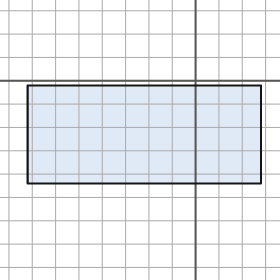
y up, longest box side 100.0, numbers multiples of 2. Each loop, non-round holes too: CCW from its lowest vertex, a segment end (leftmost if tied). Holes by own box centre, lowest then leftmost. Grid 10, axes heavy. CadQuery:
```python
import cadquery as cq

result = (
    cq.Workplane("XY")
    .moveTo(-72.0, -44.0)
    .lineTo(28.0, -44.0)
    .lineTo(28.0, -2.0)
    .lineTo(-72.0, -2.0)
    .close()
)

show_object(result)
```